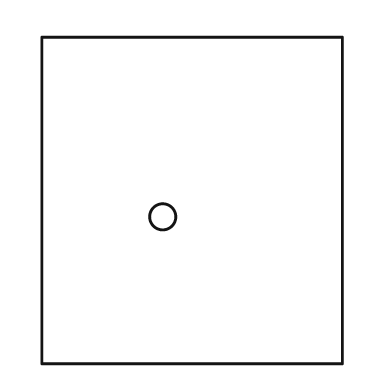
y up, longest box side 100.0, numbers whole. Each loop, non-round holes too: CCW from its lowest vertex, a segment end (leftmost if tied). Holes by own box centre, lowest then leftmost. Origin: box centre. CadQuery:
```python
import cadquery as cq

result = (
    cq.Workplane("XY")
    .moveTo(-46.0, -50.0)
    .lineTo(46.0, -50.0)
    .lineTo(46.0, 50.0)
    .lineTo(-46.0, 50.0)
    .close()
    .moveTo(-9.0, -5.0)
    .circle(4.0)
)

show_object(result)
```